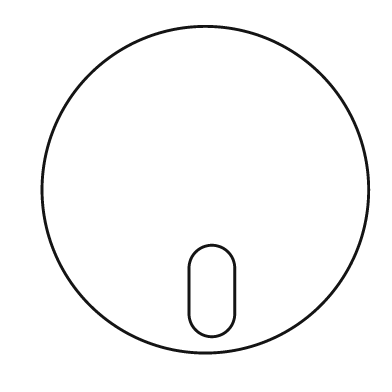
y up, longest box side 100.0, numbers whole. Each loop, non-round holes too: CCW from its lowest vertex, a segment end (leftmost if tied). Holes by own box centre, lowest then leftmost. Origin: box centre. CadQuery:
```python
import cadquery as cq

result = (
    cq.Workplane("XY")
    .moveTo(0.0, 0.0)
    .circle(50.0)
    .moveTo(-5.0, -38.0)
    .threePointArc((2.0, -45.0), (9.0, -38.0))
    .lineTo(9.0, -24.0)
    .threePointArc((2.0, -17.0), (-5.0, -24.0))
    .close()
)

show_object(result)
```